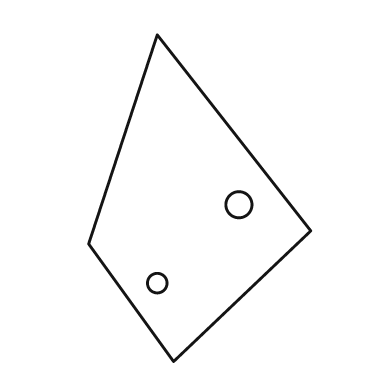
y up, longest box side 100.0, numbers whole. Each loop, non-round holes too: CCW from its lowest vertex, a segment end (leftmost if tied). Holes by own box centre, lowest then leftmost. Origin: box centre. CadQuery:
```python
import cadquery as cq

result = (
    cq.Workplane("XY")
    .moveTo(-8.0, -50.0)
    .lineTo(34.0, -10.0)
    .lineTo(-13.0, 50.0)
    .lineTo(-34.0, -14.0)
    .close()
    .moveTo(-13.0, -26.0)
    .circle(3.0)
    .moveTo(12.0, -2.0)
    .circle(4.0)
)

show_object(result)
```